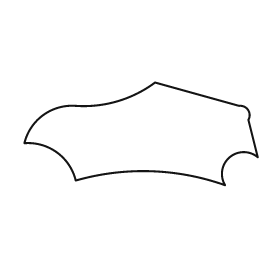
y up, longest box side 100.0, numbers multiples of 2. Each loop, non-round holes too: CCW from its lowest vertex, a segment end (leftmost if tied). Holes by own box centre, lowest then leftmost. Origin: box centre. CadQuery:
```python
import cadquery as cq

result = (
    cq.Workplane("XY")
    .moveTo(36.0, -22.0)
    .threePointArc((38.0, -10.0), (50.0, -10.0))
    .lineTo(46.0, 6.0)
    .threePointArc((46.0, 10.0), (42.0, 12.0))
    .lineTo(6.0, 22.0)
    .threePointArc((-10.0, 14.0), (-28.0, 12.0))
    .threePointArc((-42.0, 8.0), (-50.0, -4.0))
    .threePointArc((-36.0, -8.0), (-28.0, -20.0))
    .threePointArc((4.0, -16.0), (36.0, -22.0))
    .close()
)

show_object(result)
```